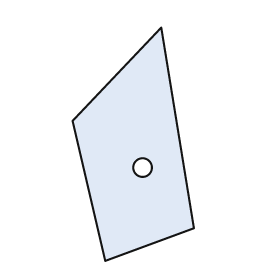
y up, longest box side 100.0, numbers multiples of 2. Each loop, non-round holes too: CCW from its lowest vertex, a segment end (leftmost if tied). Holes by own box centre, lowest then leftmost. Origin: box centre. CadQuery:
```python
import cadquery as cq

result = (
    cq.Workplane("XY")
    .moveTo(-12.0, -50.0)
    .lineTo(26.0, -36.0)
    .lineTo(12.0, 50.0)
    .lineTo(-26.0, 10.0)
    .close()
    .moveTo(4.0, -10.0)
    .circle(4.0)
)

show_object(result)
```